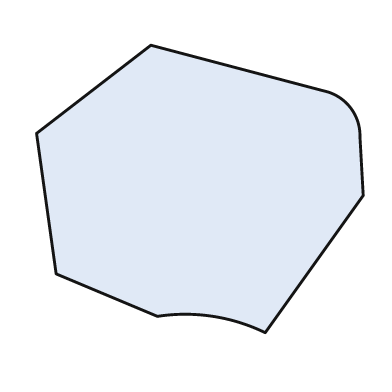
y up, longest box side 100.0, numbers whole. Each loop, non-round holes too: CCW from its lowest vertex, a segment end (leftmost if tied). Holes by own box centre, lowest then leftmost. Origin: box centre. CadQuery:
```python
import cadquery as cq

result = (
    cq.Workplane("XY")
    .moveTo(20.0, -44.0)
    .lineTo(50.0, -2.0)
    .lineTo(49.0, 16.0)
    .threePointArc((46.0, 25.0), (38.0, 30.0))
    .lineTo(-15.0, 44.0)
    .lineTo(-50.0, 17.0)
    .lineTo(-44.0, -26.0)
    .lineTo(-13.0, -39.0)
    .threePointArc((4.0, -39.0), (20.0, -44.0))
    .close()
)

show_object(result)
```